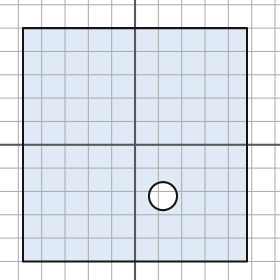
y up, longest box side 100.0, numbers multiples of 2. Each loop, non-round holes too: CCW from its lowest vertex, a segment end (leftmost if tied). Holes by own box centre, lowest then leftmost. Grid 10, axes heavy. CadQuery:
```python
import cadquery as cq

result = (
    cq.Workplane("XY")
    .moveTo(-48.0, -50.0)
    .lineTo(48.0, -50.0)
    .lineTo(48.0, 50.0)
    .lineTo(-48.0, 50.0)
    .close()
    .moveTo(12.0, -22.0)
    .circle(6.0)
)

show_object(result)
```